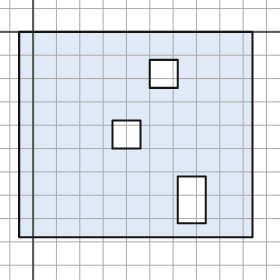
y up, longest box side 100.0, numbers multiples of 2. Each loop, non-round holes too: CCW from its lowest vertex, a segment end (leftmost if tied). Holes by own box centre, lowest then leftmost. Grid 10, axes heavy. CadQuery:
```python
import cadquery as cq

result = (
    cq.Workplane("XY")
    .moveTo(-6.0, -88.0)
    .lineTo(94.0, -88.0)
    .lineTo(94.0, 0.0)
    .lineTo(-6.0, 0.0)
    .close()
    .moveTo(62.0, -82.0)
    .lineTo(74.0, -82.0)
    .lineTo(74.0, -62.0)
    .lineTo(62.0, -62.0)
    .close()
    .moveTo(34.0, -50.0)
    .lineTo(46.0, -50.0)
    .lineTo(46.0, -38.0)
    .lineTo(34.0, -38.0)
    .close()
    .moveTo(50.0, -24.0)
    .lineTo(62.0, -24.0)
    .lineTo(62.0, -12.0)
    .lineTo(50.0, -12.0)
    .close()
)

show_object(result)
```